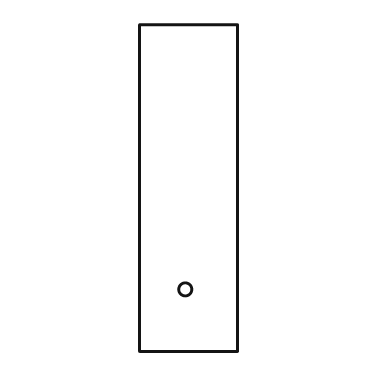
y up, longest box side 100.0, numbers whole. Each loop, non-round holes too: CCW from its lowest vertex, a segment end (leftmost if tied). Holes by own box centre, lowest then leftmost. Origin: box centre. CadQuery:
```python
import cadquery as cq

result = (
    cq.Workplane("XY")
    .moveTo(-15.0, -50.0)
    .lineTo(15.0, -50.0)
    .lineTo(15.0, 50.0)
    .lineTo(-15.0, 50.0)
    .close()
    .moveTo(-1.0, -31.0)
    .circle(2.0)
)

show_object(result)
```